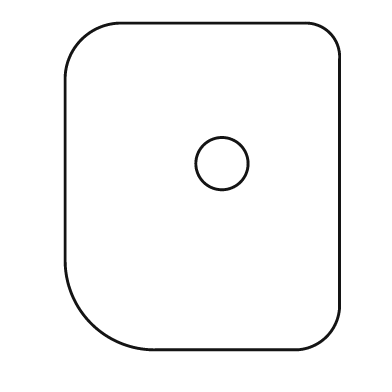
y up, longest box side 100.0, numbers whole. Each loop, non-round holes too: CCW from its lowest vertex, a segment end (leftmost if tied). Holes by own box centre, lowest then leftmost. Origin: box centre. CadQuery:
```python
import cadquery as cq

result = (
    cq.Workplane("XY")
    .moveTo(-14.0, -50.0)
    .lineTo(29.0, -50.0)
    .threePointArc((38.0, -46.0), (42.0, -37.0))
    .lineTo(42.0, 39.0)
    .threePointArc((39.0, 47.0), (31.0, 50.0))
    .lineTo(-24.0, 50.0)
    .threePointArc((-37.0, 45.0), (-42.0, 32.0))
    .lineTo(-42.0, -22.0)
    .threePointArc((-34.0, -42.0), (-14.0, -50.0))
    .close()
    .moveTo(6.0, 7.0)
    .circle(8.0)
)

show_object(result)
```